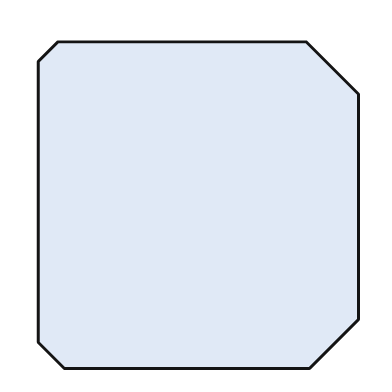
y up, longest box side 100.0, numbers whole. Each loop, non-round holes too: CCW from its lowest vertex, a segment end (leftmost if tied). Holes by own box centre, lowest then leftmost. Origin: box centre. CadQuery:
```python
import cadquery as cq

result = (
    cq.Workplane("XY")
    .moveTo(-41.0, -50.0)
    .lineTo(34.0, -50.0)
    .lineTo(49.0, -35.0)
    .lineTo(49.0, 34.0)
    .lineTo(33.0, 50.0)
    .lineTo(-43.0, 50.0)
    .lineTo(-49.0, 44.0)
    .lineTo(-49.0, -42.0)
    .close()
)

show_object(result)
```